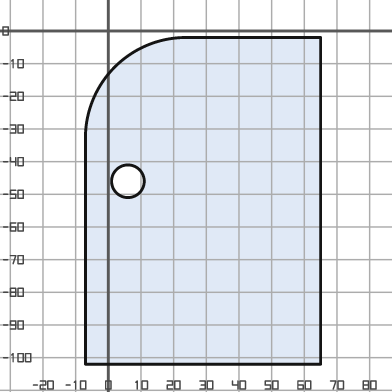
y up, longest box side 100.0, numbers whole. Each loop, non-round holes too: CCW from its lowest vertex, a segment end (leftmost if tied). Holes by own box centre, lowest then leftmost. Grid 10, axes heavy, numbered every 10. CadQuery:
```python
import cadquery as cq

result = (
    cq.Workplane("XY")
    .moveTo(-7.0, -102.0)
    .lineTo(65.0, -102.0)
    .lineTo(65.0, -2.0)
    .lineTo(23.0, -2.0)
    .threePointArc((2.0, -11.0), (-7.0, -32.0))
    .close()
    .moveTo(6.0, -46.0)
    .circle(5.0)
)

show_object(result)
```